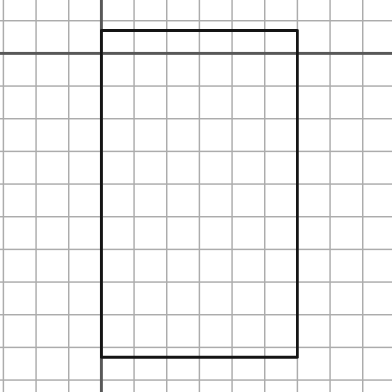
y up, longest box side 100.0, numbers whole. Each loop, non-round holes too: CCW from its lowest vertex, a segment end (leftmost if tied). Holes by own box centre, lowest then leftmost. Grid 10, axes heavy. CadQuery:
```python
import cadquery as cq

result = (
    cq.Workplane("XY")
    .moveTo(0.0, -93.0)
    .lineTo(60.0, -93.0)
    .lineTo(60.0, 7.0)
    .lineTo(0.0, 7.0)
    .close()
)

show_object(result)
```